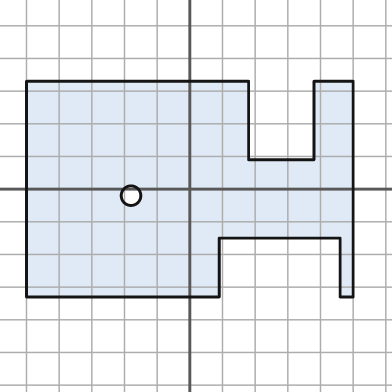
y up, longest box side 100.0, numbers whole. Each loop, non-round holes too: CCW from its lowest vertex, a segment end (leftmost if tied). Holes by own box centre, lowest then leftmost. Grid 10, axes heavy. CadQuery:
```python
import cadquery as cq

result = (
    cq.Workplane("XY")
    .moveTo(-50.0, -33.0)
    .lineTo(9.0, -33.0)
    .lineTo(9.0, -15.0)
    .lineTo(46.0, -15.0)
    .lineTo(46.0, -33.0)
    .lineTo(50.0, -33.0)
    .lineTo(50.0, 33.0)
    .lineTo(38.0, 33.0)
    .lineTo(38.0, 9.0)
    .lineTo(18.0, 9.0)
    .lineTo(18.0, 33.0)
    .lineTo(-50.0, 33.0)
    .close()
    .moveTo(-18.0, -2.0)
    .circle(3.0)
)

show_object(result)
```